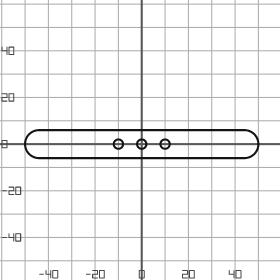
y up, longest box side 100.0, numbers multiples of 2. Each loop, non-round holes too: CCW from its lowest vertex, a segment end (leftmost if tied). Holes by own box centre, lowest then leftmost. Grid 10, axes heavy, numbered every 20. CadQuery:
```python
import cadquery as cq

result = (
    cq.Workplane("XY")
    .moveTo(-44.0, -6.0)
    .lineTo(44.0, -6.0)
    .threePointArc((50.0, 0.0), (44.0, 6.0))
    .lineTo(-44.0, 6.0)
    .threePointArc((-50.0, 0.0), (-44.0, -6.0))
    .close()
    .moveTo(-10.0, 0.0)
    .circle(2.0)
    .moveTo(0.0, 0.0)
    .circle(2.0)
    .moveTo(10.0, 0.0)
    .circle(2.0)
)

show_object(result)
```